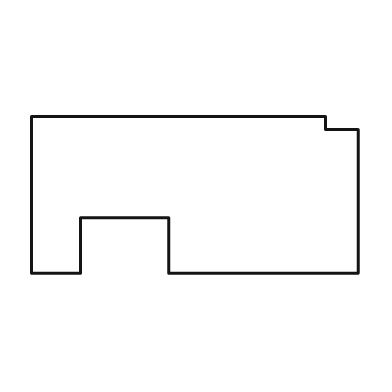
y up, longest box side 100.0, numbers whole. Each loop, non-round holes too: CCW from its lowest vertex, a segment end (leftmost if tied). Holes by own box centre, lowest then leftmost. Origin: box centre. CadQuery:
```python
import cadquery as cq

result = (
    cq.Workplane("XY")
    .moveTo(-50.0, -24.0)
    .lineTo(-35.0, -24.0)
    .lineTo(-35.0, -7.0)
    .lineTo(-8.0, -7.0)
    .lineTo(-8.0, -24.0)
    .lineTo(50.0, -24.0)
    .lineTo(50.0, 20.0)
    .lineTo(40.0, 20.0)
    .lineTo(40.0, 24.0)
    .lineTo(-50.0, 24.0)
    .close()
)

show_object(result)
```